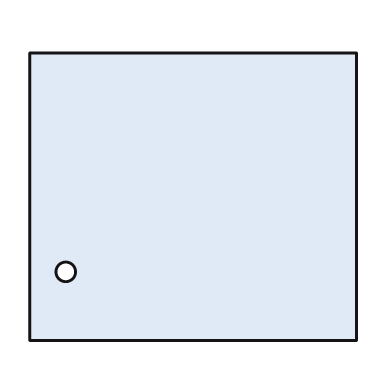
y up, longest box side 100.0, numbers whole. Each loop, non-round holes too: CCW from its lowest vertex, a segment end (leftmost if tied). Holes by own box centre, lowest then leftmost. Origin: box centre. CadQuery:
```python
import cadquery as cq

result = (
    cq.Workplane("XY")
    .moveTo(-50.0, -44.0)
    .lineTo(50.0, -44.0)
    .lineTo(50.0, 44.0)
    .lineTo(-50.0, 44.0)
    .close()
    .moveTo(-39.0, -23.0)
    .circle(3.0)
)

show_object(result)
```